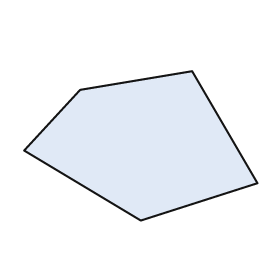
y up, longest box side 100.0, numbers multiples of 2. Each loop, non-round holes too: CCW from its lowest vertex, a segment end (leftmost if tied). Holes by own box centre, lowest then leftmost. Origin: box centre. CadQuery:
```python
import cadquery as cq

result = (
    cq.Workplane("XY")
    .moveTo(0.0, -32.0)
    .lineTo(50.0, -16.0)
    .lineTo(22.0, 32.0)
    .lineTo(-26.0, 24.0)
    .lineTo(-50.0, -2.0)
    .close()
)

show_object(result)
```